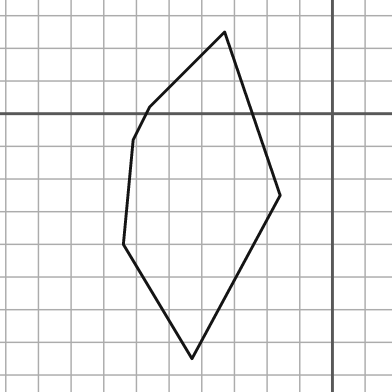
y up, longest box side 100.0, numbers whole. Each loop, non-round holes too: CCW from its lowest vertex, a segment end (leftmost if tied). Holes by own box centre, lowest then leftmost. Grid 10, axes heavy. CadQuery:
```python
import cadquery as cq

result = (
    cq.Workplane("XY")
    .moveTo(-43.0, -75.0)
    .lineTo(-16.0, -25.0)
    .lineTo(-33.0, 25.0)
    .lineTo(-56.0, 2.0)
    .lineTo(-61.0, -8.0)
    .lineTo(-64.0, -40.0)
    .close()
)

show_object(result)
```